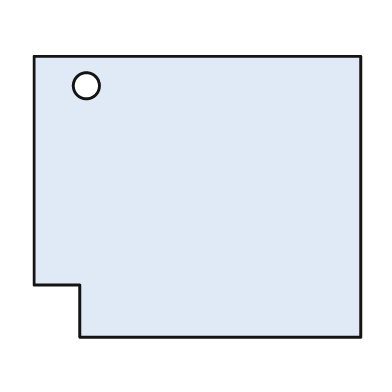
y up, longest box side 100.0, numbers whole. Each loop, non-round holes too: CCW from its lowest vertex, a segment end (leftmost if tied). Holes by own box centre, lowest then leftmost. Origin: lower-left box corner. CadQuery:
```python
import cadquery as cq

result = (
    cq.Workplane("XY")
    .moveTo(14.0, 0.0)
    .lineTo(100.0, 0.0)
    .lineTo(100.0, 86.0)
    .lineTo(0.0, 86.0)
    .lineTo(0.0, 16.0)
    .lineTo(14.0, 16.0)
    .close()
    .moveTo(16.0, 77.0)
    .circle(4.0)
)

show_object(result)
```